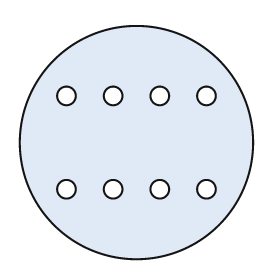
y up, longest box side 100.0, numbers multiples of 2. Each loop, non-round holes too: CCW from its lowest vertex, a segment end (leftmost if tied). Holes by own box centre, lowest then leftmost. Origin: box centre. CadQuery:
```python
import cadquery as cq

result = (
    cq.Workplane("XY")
    .moveTo(0.0, 0.0)
    .circle(50.0)
    .moveTo(-30.0, -20.0)
    .circle(4.0)
    .moveTo(-10.0, -20.0)
    .circle(4.0)
    .moveTo(10.0, -20.0)
    .circle(4.0)
    .moveTo(30.0, -20.0)
    .circle(4.0)
    .moveTo(-30.0, 20.0)
    .circle(4.0)
    .moveTo(-10.0, 20.0)
    .circle(4.0)
    .moveTo(10.0, 20.0)
    .circle(4.0)
    .moveTo(30.0, 20.0)
    .circle(4.0)
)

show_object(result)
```